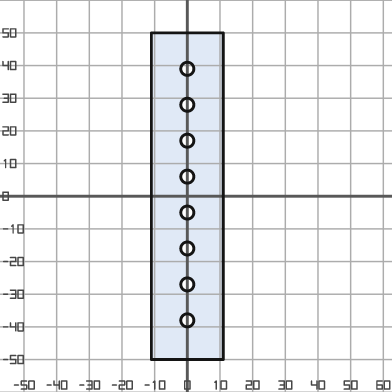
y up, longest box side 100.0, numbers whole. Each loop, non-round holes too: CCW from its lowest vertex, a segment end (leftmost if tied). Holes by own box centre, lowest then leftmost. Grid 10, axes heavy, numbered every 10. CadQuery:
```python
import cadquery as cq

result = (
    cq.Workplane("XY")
    .moveTo(-11.0, -50.0)
    .lineTo(11.0, -50.0)
    .lineTo(11.0, 50.0)
    .lineTo(-11.0, 50.0)
    .close()
    .moveTo(0.0, -38.0)
    .circle(2.0)
    .moveTo(0.0, -27.0)
    .circle(2.0)
    .moveTo(0.0, -16.0)
    .circle(2.0)
    .moveTo(0.0, -5.0)
    .circle(2.0)
    .moveTo(0.0, 6.0)
    .circle(2.0)
    .moveTo(0.0, 17.0)
    .circle(2.0)
    .moveTo(0.0, 28.0)
    .circle(2.0)
    .moveTo(0.0, 39.0)
    .circle(2.0)
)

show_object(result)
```